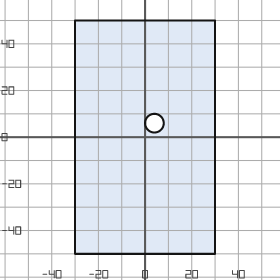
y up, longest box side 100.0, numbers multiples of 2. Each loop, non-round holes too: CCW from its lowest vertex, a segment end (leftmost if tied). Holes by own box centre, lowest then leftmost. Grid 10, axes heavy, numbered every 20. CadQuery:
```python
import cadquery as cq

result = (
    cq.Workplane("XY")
    .moveTo(-30.0, -50.0)
    .lineTo(30.0, -50.0)
    .lineTo(30.0, 50.0)
    .lineTo(-30.0, 50.0)
    .close()
    .moveTo(4.0, 6.0)
    .circle(4.0)
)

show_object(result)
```